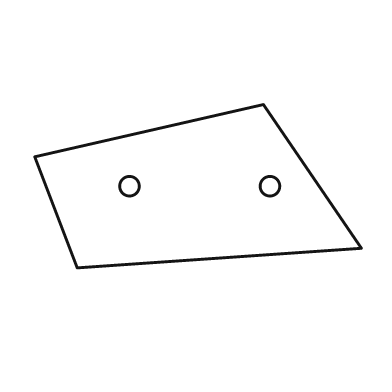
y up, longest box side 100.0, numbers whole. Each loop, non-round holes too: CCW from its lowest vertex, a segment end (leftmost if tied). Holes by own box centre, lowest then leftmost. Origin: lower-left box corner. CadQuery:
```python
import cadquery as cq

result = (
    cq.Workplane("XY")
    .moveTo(13.0, 0.0)
    .lineTo(100.0, 6.0)
    .lineTo(70.0, 50.0)
    .lineTo(0.0, 34.0)
    .close()
    .moveTo(29.0, 25.0)
    .circle(3.0)
    .moveTo(72.0, 25.0)
    .circle(3.0)
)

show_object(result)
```